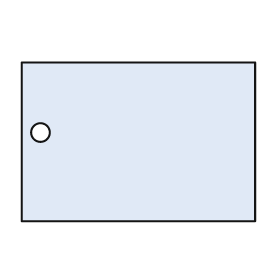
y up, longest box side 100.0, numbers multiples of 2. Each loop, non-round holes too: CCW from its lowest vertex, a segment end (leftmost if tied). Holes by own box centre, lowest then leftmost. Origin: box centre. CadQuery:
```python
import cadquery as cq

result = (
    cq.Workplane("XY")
    .moveTo(-50.0, -34.0)
    .lineTo(50.0, -34.0)
    .lineTo(50.0, 34.0)
    .lineTo(-50.0, 34.0)
    .close()
    .moveTo(-42.0, 4.0)
    .circle(4.0)
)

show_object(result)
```